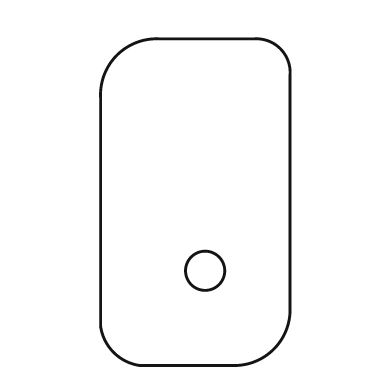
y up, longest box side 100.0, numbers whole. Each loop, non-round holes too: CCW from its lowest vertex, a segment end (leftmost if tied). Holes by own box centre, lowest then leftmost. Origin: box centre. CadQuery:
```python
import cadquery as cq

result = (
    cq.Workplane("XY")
    .moveTo(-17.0, -50.0)
    .lineTo(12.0, -50.0)
    .threePointArc((24.0, -45.0), (29.0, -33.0))
    .lineTo(29.0, 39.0)
    .threePointArc((26.0, 47.0), (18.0, 50.0))
    .lineTo(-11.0, 50.0)
    .threePointArc((-24.0, 45.0), (-29.0, 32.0))
    .lineTo(-29.0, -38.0)
    .threePointArc((-25.0, -46.0), (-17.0, -50.0))
    .close()
    .moveTo(3.0, -21.0)
    .circle(6.0)
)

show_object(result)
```